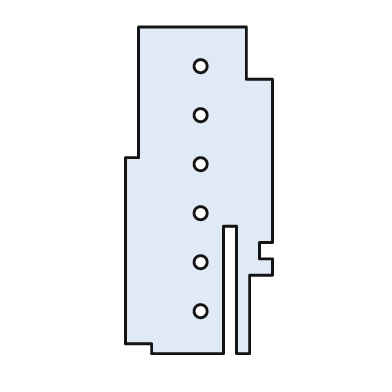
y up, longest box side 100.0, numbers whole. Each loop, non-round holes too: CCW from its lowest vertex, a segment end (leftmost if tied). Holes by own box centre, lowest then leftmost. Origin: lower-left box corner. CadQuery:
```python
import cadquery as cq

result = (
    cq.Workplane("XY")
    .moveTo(8.0, 0.0)
    .lineTo(30.0, 0.0)
    .lineTo(30.0, 39.0)
    .lineTo(34.0, 39.0)
    .lineTo(34.0, 0.0)
    .lineTo(38.0, 0.0)
    .lineTo(38.0, 24.0)
    .lineTo(45.0, 24.0)
    .lineTo(45.0, 29.0)
    .lineTo(41.0, 29.0)
    .lineTo(41.0, 34.0)
    .lineTo(45.0, 34.0)
    .lineTo(45.0, 84.0)
    .lineTo(37.0, 84.0)
    .lineTo(37.0, 100.0)
    .lineTo(4.0, 100.0)
    .lineTo(4.0, 60.0)
    .lineTo(0.0, 60.0)
    .lineTo(0.0, 3.0)
    .lineTo(8.0, 3.0)
    .close()
    .moveTo(23.0, 13.0)
    .circle(2.0)
    .moveTo(23.0, 28.0)
    .circle(2.0)
    .moveTo(23.0, 43.0)
    .circle(2.0)
    .moveTo(23.0, 58.0)
    .circle(2.0)
    .moveTo(23.0, 73.0)
    .circle(2.0)
    .moveTo(23.0, 88.0)
    .circle(2.0)
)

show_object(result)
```